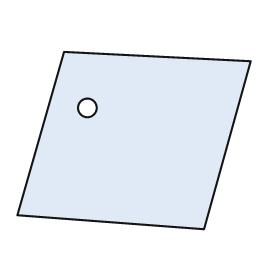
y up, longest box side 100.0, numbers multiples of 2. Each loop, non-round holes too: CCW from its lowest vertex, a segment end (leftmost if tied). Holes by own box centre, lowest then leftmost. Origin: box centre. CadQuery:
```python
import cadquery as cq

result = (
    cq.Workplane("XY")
    .moveTo(30.0, -38.0)
    .lineTo(50.0, 34.0)
    .lineTo(-30.0, 38.0)
    .lineTo(-50.0, -32.0)
    .close()
    .moveTo(-20.0, 14.0)
    .circle(4.0)
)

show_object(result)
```